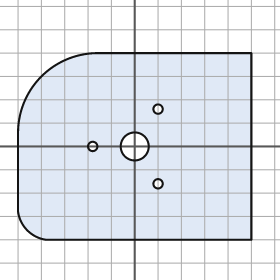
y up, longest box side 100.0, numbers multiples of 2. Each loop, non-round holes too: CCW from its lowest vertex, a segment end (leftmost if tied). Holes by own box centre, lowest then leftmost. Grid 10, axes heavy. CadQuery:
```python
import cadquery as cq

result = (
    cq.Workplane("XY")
    .moveTo(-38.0, -40.0)
    .lineTo(50.0, -40.0)
    .lineTo(50.0, 40.0)
    .lineTo(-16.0, 40.0)
    .threePointArc((-40.0, 30.0), (-50.0, 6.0))
    .lineTo(-50.0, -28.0)
    .threePointArc((-46.0, -36.0), (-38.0, -40.0))
    .close()
    .moveTo(10.0, -16.0)
    .circle(2.0)
    .moveTo(-18.0, 0.0)
    .circle(2.0)
    .moveTo(0.0, 0.0)
    .circle(6.0)
    .moveTo(10.0, 16.0)
    .circle(2.0)
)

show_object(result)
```